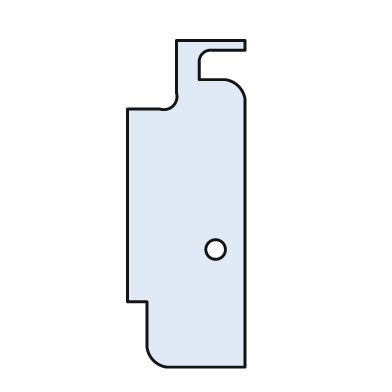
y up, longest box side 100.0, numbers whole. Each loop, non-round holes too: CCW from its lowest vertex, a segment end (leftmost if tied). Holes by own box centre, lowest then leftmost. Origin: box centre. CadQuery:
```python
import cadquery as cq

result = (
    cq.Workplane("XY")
    .moveTo(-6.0, -50.0)
    .lineTo(18.0, -50.0)
    .lineTo(18.0, 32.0)
    .threePointArc((16.0, 36.0), (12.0, 38.0))
    .lineTo(4.0, 38.0)
    .lineTo(4.0, 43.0)
    .threePointArc((5.0, 46.0), (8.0, 47.0))
    .lineTo(18.0, 47.0)
    .lineTo(18.0, 50.0)
    .lineTo(-3.0, 50.0)
    .lineTo(-3.0, 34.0)
    .threePointArc((-4.0, 30.0), (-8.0, 29.0))
    .lineTo(-18.0, 29.0)
    .lineTo(-18.0, -30.0)
    .lineTo(-12.0, -30.0)
    .lineTo(-12.0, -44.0)
    .threePointArc((-10.0, -48.0), (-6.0, -50.0))
    .close()
    .moveTo(9.0, -14.0)
    .circle(3.0)
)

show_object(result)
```